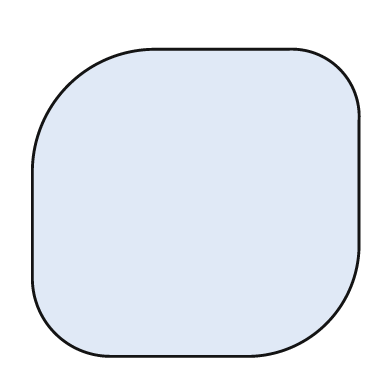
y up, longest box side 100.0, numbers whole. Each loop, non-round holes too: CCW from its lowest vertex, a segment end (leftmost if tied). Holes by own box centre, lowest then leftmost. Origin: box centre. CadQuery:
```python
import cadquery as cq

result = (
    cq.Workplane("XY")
    .moveTo(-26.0, -47.0)
    .lineTo(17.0, -47.0)
    .threePointArc((40.0, -37.0), (50.0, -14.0))
    .lineTo(50.0, 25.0)
    .threePointArc((44.0, 41.0), (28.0, 47.0))
    .lineTo(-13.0, 47.0)
    .threePointArc((-39.0, 36.0), (-50.0, 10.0))
    .lineTo(-50.0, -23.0)
    .threePointArc((-43.0, -40.0), (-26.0, -47.0))
    .close()
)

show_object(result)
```